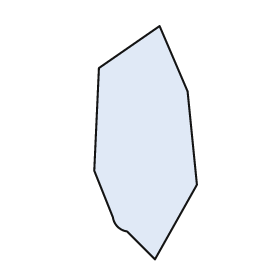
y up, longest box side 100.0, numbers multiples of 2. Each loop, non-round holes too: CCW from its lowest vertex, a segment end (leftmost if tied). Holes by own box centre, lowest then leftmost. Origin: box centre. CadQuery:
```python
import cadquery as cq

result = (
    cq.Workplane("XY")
    .moveTo(4.0, -50.0)
    .lineTo(22.0, -18.0)
    .lineTo(18.0, 22.0)
    .lineTo(6.0, 50.0)
    .lineTo(-20.0, 32.0)
    .lineTo(-22.0, -12.0)
    .lineTo(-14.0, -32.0)
    .threePointArc((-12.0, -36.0), (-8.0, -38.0))
    .close()
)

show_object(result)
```